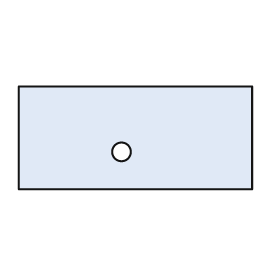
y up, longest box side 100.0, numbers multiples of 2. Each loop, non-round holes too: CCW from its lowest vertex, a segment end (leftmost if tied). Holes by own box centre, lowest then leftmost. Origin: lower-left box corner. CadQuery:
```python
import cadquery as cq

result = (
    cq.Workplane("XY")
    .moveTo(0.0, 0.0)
    .lineTo(100.0, 0.0)
    .lineTo(100.0, 44.0)
    .lineTo(0.0, 44.0)
    .close()
    .moveTo(44.0, 16.0)
    .circle(4.0)
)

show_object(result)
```